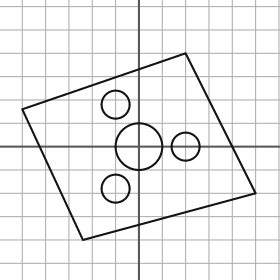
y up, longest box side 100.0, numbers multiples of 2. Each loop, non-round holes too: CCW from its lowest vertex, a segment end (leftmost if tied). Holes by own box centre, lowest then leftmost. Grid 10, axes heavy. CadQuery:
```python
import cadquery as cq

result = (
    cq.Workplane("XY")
    .moveTo(-24.0, -40.0)
    .lineTo(50.0, -20.0)
    .lineTo(20.0, 40.0)
    .lineTo(-50.0, 16.0)
    .close()
    .moveTo(-10.0, -18.0)
    .circle(6.0)
    .moveTo(0.0, 0.0)
    .circle(10.0)
    .moveTo(20.0, 0.0)
    .circle(6.0)
    .moveTo(-10.0, 18.0)
    .circle(6.0)
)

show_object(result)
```